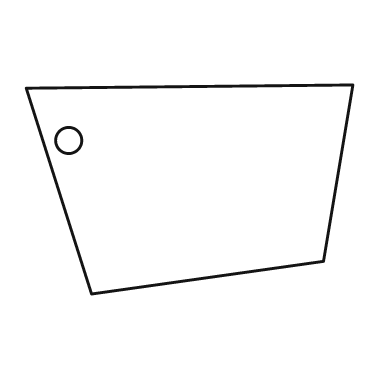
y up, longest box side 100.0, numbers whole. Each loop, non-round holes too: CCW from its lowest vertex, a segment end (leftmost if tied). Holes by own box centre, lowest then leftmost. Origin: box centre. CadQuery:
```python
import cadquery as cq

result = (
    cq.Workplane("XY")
    .moveTo(-30.0, -32.0)
    .lineTo(41.0, -22.0)
    .lineTo(50.0, 32.0)
    .lineTo(-50.0, 31.0)
    .close()
    .moveTo(-37.0, 15.0)
    .circle(4.0)
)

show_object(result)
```